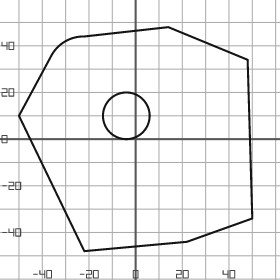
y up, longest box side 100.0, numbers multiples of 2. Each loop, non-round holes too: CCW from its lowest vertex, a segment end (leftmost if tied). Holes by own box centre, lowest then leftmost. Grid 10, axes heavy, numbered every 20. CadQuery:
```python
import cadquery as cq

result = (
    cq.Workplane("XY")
    .moveTo(-22.0, -48.0)
    .lineTo(22.0, -44.0)
    .lineTo(50.0, -34.0)
    .lineTo(48.0, 34.0)
    .lineTo(14.0, 48.0)
    .lineTo(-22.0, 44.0)
    .threePointArc((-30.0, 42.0), (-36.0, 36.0))
    .lineTo(-50.0, 10.0)
    .close()
    .moveTo(-4.0, 10.0)
    .circle(10.0)
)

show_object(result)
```